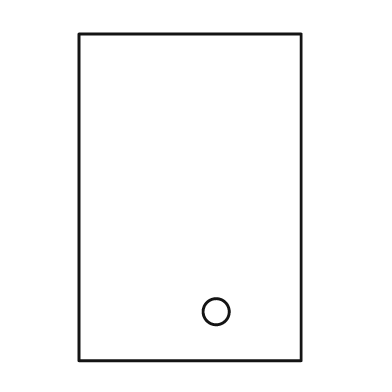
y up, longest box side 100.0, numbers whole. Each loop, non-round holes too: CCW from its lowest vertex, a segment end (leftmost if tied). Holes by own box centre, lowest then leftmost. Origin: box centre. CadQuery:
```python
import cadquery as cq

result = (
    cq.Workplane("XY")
    .moveTo(-34.0, -50.0)
    .lineTo(34.0, -50.0)
    .lineTo(34.0, 50.0)
    .lineTo(-34.0, 50.0)
    .close()
    .moveTo(8.0, -35.0)
    .circle(4.0)
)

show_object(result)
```